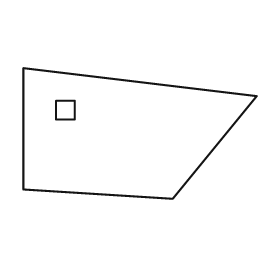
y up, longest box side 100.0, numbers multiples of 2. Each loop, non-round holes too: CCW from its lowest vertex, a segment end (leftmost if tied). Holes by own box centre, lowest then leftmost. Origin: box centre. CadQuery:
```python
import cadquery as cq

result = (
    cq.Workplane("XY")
    .moveTo(14.0, -28.0)
    .lineTo(50.0, 16.0)
    .lineTo(-50.0, 28.0)
    .lineTo(-50.0, -24.0)
    .close()
    .moveTo(-36.0, 6.0)
    .lineTo(-28.0, 6.0)
    .lineTo(-28.0, 14.0)
    .lineTo(-36.0, 14.0)
    .close()
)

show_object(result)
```